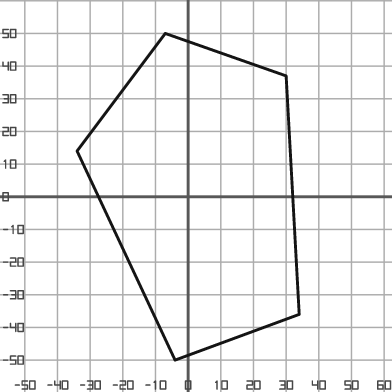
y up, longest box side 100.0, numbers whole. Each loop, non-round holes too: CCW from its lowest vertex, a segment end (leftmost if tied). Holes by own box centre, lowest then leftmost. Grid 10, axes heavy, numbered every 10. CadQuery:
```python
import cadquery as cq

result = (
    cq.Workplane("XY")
    .moveTo(-4.0, -50.0)
    .lineTo(34.0, -36.0)
    .lineTo(30.0, 37.0)
    .lineTo(-7.0, 50.0)
    .lineTo(-34.0, 14.0)
    .close()
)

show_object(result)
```